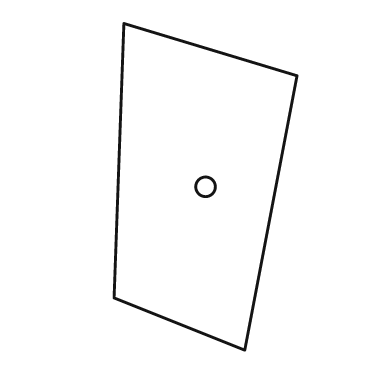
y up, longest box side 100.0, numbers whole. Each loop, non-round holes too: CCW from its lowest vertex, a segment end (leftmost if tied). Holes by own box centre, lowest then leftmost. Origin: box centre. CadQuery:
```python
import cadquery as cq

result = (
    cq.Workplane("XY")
    .moveTo(12.0, -50.0)
    .lineTo(28.0, 34.0)
    .lineTo(-25.0, 50.0)
    .lineTo(-28.0, -34.0)
    .close()
    .moveTo(0.0, 0.0)
    .circle(3.0)
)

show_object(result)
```